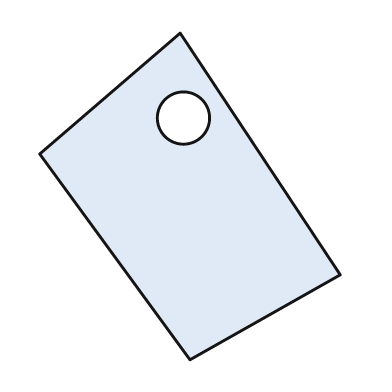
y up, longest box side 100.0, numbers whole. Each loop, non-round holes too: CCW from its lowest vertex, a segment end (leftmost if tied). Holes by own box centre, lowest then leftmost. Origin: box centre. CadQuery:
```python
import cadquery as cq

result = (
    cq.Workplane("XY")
    .moveTo(0.0, -50.0)
    .lineTo(46.0, -24.0)
    .lineTo(-3.0, 50.0)
    .lineTo(-46.0, 13.0)
    .close()
    .moveTo(-2.0, 24.0)
    .circle(8.0)
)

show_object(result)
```